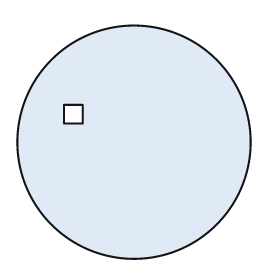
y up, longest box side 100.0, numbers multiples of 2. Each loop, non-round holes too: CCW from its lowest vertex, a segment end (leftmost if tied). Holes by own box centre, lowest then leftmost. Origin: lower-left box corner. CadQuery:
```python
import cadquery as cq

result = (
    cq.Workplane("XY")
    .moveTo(50.0, 50.0)
    .circle(50.0)
    .moveTo(20.0, 58.0)
    .lineTo(28.0, 58.0)
    .lineTo(28.0, 66.0)
    .lineTo(20.0, 66.0)
    .close()
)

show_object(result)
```